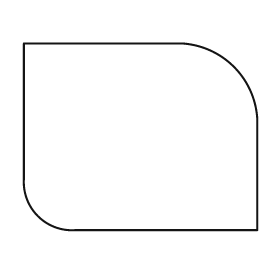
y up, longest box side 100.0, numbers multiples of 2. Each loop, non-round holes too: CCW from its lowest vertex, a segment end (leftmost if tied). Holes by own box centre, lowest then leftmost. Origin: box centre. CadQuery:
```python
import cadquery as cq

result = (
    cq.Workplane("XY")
    .moveTo(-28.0, -40.0)
    .lineTo(50.0, -40.0)
    .lineTo(50.0, 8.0)
    .threePointArc((40.0, 30.0), (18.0, 40.0))
    .lineTo(-50.0, 40.0)
    .lineTo(-50.0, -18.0)
    .threePointArc((-44.0, -34.0), (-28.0, -40.0))
    .close()
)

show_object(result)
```